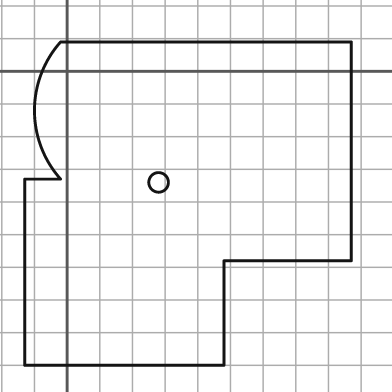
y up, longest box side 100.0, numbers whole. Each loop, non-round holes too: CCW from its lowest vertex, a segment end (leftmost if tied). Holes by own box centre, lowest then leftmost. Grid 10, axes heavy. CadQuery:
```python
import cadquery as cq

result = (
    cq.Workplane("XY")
    .moveTo(-13.0, -90.0)
    .lineTo(48.0, -90.0)
    .lineTo(48.0, -58.0)
    .lineTo(87.0, -58.0)
    .lineTo(87.0, 9.0)
    .lineTo(-2.0, 9.0)
    .threePointArc((-10.0, -12.0), (-2.0, -33.0))
    .lineTo(-13.0, -33.0)
    .close()
    .moveTo(28.0, -34.0)
    .circle(3.0)
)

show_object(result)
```